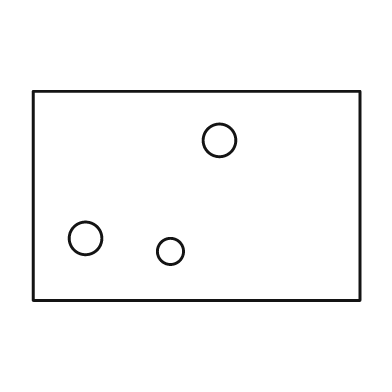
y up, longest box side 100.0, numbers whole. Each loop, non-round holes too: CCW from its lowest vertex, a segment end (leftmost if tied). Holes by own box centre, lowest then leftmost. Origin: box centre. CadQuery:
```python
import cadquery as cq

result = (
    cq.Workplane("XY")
    .moveTo(-50.0, -32.0)
    .lineTo(50.0, -32.0)
    .lineTo(50.0, 32.0)
    .lineTo(-50.0, 32.0)
    .close()
    .moveTo(-8.0, -17.0)
    .circle(4.0)
    .moveTo(-34.0, -13.0)
    .circle(5.0)
    .moveTo(7.0, 17.0)
    .circle(5.0)
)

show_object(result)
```